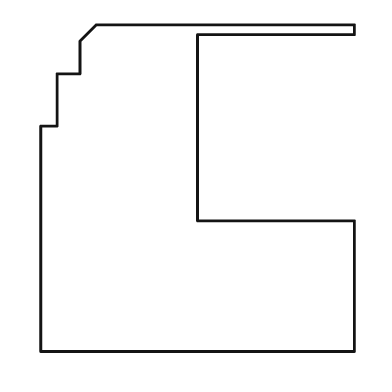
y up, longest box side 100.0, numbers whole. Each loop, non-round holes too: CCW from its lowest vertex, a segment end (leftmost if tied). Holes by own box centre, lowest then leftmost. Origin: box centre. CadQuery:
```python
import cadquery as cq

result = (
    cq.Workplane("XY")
    .moveTo(-48.0, -50.0)
    .lineTo(48.0, -50.0)
    .lineTo(48.0, -10.0)
    .lineTo(0.0, -10.0)
    .lineTo(0.0, 47.0)
    .lineTo(48.0, 47.0)
    .lineTo(48.0, 50.0)
    .lineTo(-31.0, 50.0)
    .lineTo(-36.0, 45.0)
    .lineTo(-36.0, 35.0)
    .lineTo(-43.0, 35.0)
    .lineTo(-43.0, 19.0)
    .lineTo(-48.0, 19.0)
    .close()
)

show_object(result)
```